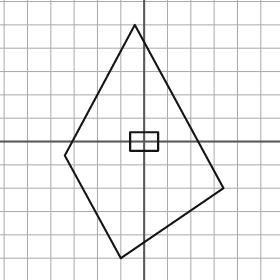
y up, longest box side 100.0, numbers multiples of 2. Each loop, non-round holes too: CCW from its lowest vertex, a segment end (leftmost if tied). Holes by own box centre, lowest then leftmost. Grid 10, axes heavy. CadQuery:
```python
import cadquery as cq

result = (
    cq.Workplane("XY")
    .moveTo(-10.0, -50.0)
    .lineTo(34.0, -20.0)
    .lineTo(-4.0, 50.0)
    .lineTo(-34.0, -6.0)
    .close()
    .moveTo(-6.0, -4.0)
    .lineTo(6.0, -4.0)
    .lineTo(6.0, 4.0)
    .lineTo(-6.0, 4.0)
    .close()
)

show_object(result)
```